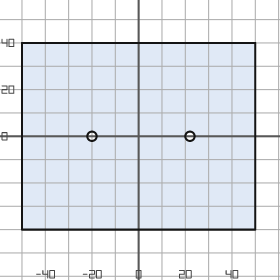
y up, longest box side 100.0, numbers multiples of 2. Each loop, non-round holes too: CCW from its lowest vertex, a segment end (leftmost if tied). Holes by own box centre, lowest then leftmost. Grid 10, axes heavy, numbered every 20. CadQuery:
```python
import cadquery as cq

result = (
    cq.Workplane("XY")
    .moveTo(-50.0, -40.0)
    .lineTo(50.0, -40.0)
    .lineTo(50.0, 40.0)
    .lineTo(-50.0, 40.0)
    .close()
    .moveTo(-20.0, 0.0)
    .circle(2.0)
    .moveTo(22.0, 0.0)
    .circle(2.0)
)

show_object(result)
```